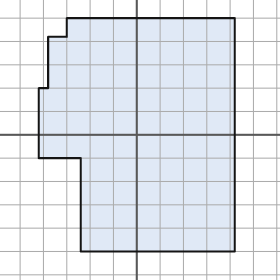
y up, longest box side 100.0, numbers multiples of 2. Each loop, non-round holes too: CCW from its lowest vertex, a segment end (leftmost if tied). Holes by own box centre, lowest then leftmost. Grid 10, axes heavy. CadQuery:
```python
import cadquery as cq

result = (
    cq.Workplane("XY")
    .moveTo(-24.0, -50.0)
    .lineTo(42.0, -50.0)
    .lineTo(42.0, 50.0)
    .lineTo(-30.0, 50.0)
    .lineTo(-30.0, 42.0)
    .lineTo(-38.0, 42.0)
    .lineTo(-38.0, 20.0)
    .lineTo(-42.0, 20.0)
    .lineTo(-42.0, -10.0)
    .lineTo(-24.0, -10.0)
    .close()
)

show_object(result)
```